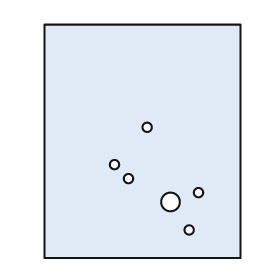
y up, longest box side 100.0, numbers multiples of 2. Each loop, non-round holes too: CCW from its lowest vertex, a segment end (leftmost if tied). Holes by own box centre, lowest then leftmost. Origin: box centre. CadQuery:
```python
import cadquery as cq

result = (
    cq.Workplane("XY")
    .moveTo(-42.0, -50.0)
    .lineTo(42.0, -50.0)
    .lineTo(42.0, 50.0)
    .lineTo(-42.0, 50.0)
    .close()
    .moveTo(20.0, -38.0)
    .circle(2.0)
    .moveTo(12.0, -26.0)
    .circle(4.0)
    .moveTo(24.0, -22.0)
    .circle(2.0)
    .moveTo(-6.0, -16.0)
    .circle(2.0)
    .moveTo(-12.0, -10.0)
    .circle(2.0)
    .moveTo(2.0, 6.0)
    .circle(2.0)
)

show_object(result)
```